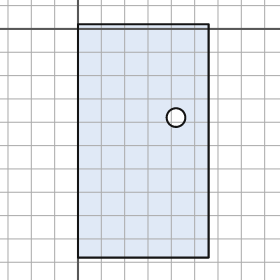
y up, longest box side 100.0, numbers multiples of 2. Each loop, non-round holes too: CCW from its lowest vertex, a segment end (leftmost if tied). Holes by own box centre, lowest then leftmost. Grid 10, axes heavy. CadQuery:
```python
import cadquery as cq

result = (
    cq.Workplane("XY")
    .moveTo(0.0, -98.0)
    .lineTo(56.0, -98.0)
    .lineTo(56.0, 2.0)
    .lineTo(0.0, 2.0)
    .close()
    .moveTo(42.0, -38.0)
    .circle(4.0)
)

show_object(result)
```